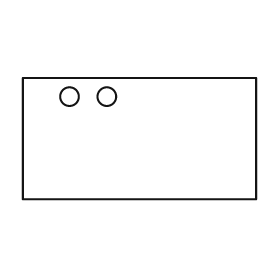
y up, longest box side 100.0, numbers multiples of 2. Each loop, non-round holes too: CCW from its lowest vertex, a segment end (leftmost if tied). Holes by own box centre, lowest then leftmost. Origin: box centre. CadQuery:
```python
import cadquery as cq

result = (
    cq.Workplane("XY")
    .moveTo(-50.0, -26.0)
    .lineTo(50.0, -26.0)
    .lineTo(50.0, 26.0)
    .lineTo(-50.0, 26.0)
    .close()
    .moveTo(-30.0, 18.0)
    .circle(4.0)
    .moveTo(-14.0, 18.0)
    .circle(4.0)
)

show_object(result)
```